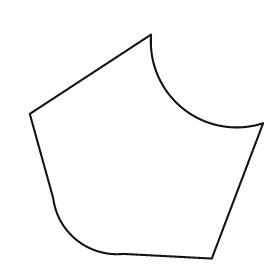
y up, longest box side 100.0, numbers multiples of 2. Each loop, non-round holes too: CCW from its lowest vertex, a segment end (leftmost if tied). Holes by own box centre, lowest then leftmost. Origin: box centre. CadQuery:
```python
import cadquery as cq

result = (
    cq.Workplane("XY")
    .moveTo(28.0, -48.0)
    .lineTo(50.0, 10.0)
    .threePointArc((16.0, 16.0), (2.0, 48.0))
    .lineTo(-50.0, 14.0)
    .lineTo(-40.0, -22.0)
    .threePointArc((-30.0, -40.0), (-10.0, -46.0))
    .close()
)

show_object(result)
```